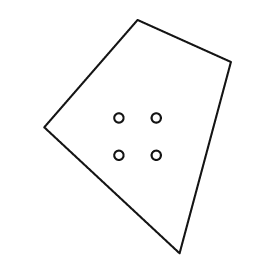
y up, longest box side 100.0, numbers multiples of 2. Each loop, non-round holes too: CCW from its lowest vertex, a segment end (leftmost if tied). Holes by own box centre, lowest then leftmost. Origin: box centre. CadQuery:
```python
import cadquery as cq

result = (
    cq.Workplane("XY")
    .moveTo(18.0, -50.0)
    .lineTo(40.0, 32.0)
    .lineTo(0.0, 50.0)
    .lineTo(-40.0, 4.0)
    .close()
    .moveTo(-8.0, -8.0)
    .circle(2.0)
    .moveTo(8.0, -8.0)
    .circle(2.0)
    .moveTo(-8.0, 8.0)
    .circle(2.0)
    .moveTo(8.0, 8.0)
    .circle(2.0)
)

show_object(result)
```